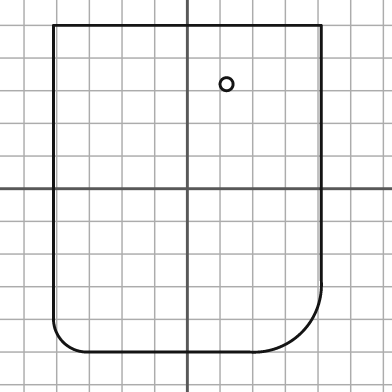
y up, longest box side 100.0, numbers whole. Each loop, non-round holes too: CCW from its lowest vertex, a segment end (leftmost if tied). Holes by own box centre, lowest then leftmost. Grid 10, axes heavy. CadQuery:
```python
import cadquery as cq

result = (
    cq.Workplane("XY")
    .moveTo(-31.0, -50.0)
    .lineTo(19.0, -50.0)
    .threePointArc((35.0, -44.0), (41.0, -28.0))
    .lineTo(41.0, 50.0)
    .lineTo(-41.0, 50.0)
    .lineTo(-41.0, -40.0)
    .threePointArc((-38.0, -47.0), (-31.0, -50.0))
    .close()
    .moveTo(12.0, 32.0)
    .circle(2.0)
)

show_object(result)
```